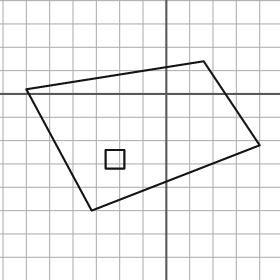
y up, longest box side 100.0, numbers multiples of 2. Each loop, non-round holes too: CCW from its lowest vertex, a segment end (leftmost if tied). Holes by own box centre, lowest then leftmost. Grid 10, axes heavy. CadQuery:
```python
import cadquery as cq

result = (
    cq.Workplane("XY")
    .moveTo(-32.0, -50.0)
    .lineTo(40.0, -22.0)
    .lineTo(16.0, 14.0)
    .lineTo(-60.0, 2.0)
    .close()
    .moveTo(-26.0, -32.0)
    .lineTo(-18.0, -32.0)
    .lineTo(-18.0, -24.0)
    .lineTo(-26.0, -24.0)
    .close()
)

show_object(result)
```